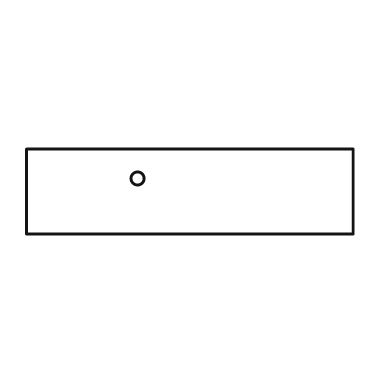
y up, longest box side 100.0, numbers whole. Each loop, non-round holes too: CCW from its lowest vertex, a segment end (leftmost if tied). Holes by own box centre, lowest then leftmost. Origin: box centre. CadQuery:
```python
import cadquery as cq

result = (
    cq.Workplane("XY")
    .moveTo(-50.0, -13.0)
    .lineTo(50.0, -13.0)
    .lineTo(50.0, 13.0)
    .lineTo(-50.0, 13.0)
    .close()
    .moveTo(-16.0, 4.0)
    .circle(2.0)
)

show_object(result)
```